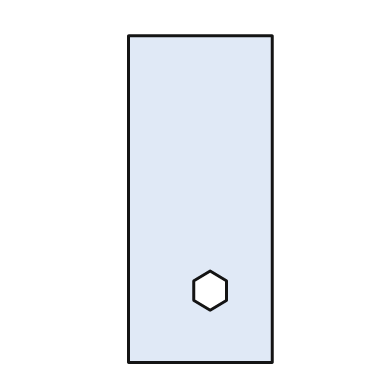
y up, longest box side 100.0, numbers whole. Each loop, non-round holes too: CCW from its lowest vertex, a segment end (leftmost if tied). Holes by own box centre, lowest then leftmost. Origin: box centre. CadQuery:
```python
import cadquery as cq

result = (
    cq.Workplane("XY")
    .moveTo(-22.0, -50.0)
    .lineTo(22.0, -50.0)
    .lineTo(22.0, 50.0)
    .lineTo(-22.0, 50.0)
    .close()
    .moveTo(3.0, -34.0)
    .lineTo(8.0, -31.0)
    .lineTo(8.0, -25.0)
    .lineTo(3.0, -22.0)
    .lineTo(-2.0, -25.0)
    .lineTo(-2.0, -31.0)
    .close()
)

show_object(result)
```